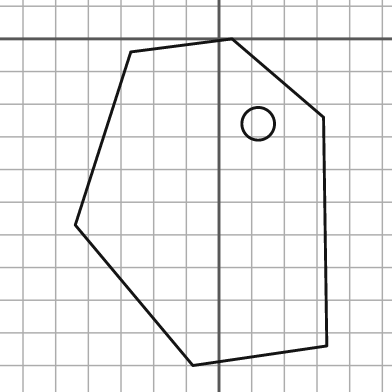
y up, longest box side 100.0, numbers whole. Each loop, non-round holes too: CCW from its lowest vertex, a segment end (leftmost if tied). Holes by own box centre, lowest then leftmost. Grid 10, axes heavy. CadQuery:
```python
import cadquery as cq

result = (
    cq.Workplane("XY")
    .moveTo(-8.0, -100.0)
    .lineTo(33.0, -94.0)
    .lineTo(32.0, -24.0)
    .lineTo(4.0, 0.0)
    .lineTo(-27.0, -4.0)
    .lineTo(-44.0, -57.0)
    .close()
    .moveTo(12.0, -26.0)
    .circle(5.0)
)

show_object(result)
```